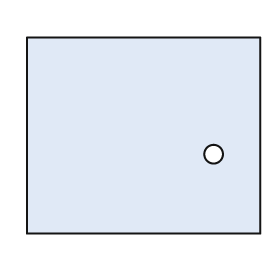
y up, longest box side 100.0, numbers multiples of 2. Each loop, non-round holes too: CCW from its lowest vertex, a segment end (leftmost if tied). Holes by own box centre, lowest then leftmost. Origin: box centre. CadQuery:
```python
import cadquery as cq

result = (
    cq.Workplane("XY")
    .moveTo(-50.0, -42.0)
    .lineTo(50.0, -42.0)
    .lineTo(50.0, 42.0)
    .lineTo(-50.0, 42.0)
    .close()
    .moveTo(30.0, -8.0)
    .circle(4.0)
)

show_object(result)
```